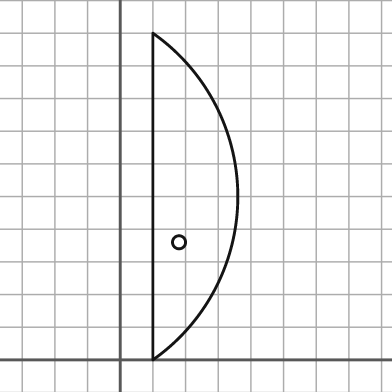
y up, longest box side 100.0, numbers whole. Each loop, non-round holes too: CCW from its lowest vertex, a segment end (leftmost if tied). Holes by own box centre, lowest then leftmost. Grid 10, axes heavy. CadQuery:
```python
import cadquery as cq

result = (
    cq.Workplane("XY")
    .moveTo(10.0, 0.0)
    .threePointArc((36.0, 50.0), (10.0, 100.0))
    .close()
    .moveTo(18.0, 36.0)
    .circle(2.0)
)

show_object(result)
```